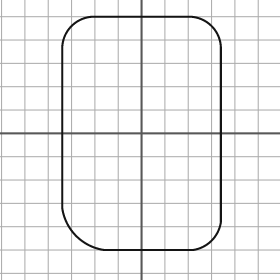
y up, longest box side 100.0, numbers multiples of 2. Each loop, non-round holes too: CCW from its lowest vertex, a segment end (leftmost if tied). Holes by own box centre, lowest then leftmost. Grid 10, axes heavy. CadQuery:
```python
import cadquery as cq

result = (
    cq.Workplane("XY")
    .moveTo(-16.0, -50.0)
    .lineTo(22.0, -50.0)
    .threePointArc((30.0, -46.0), (34.0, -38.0))
    .lineTo(34.0, 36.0)
    .threePointArc((30.0, 46.0), (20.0, 50.0))
    .lineTo(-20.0, 50.0)
    .threePointArc((-30.0, 46.0), (-34.0, 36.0))
    .lineTo(-34.0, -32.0)
    .threePointArc((-28.0, -44.0), (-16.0, -50.0))
    .close()
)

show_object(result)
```